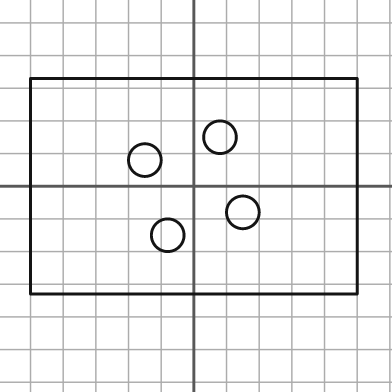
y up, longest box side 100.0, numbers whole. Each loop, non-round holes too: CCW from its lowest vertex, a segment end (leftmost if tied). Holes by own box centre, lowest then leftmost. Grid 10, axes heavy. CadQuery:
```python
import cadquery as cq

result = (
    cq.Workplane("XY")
    .moveTo(-50.0, -33.0)
    .lineTo(50.0, -33.0)
    .lineTo(50.0, 33.0)
    .lineTo(-50.0, 33.0)
    .close()
    .moveTo(-8.0, -15.0)
    .circle(5.0)
    .moveTo(15.0, -8.0)
    .circle(5.0)
    .moveTo(-15.0, 8.0)
    .circle(5.0)
    .moveTo(8.0, 15.0)
    .circle(5.0)
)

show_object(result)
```